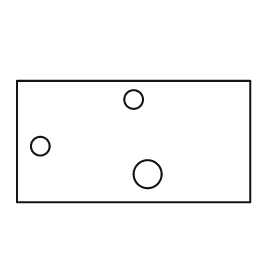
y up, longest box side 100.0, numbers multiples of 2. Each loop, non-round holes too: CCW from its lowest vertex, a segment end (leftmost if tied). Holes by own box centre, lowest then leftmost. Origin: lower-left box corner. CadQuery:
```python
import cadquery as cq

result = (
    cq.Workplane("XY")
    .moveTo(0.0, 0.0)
    .lineTo(100.0, 0.0)
    .lineTo(100.0, 52.0)
    .lineTo(0.0, 52.0)
    .close()
    .moveTo(56.0, 12.0)
    .circle(6.0)
    .moveTo(10.0, 24.0)
    .circle(4.0)
    .moveTo(50.0, 44.0)
    .circle(4.0)
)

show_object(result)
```